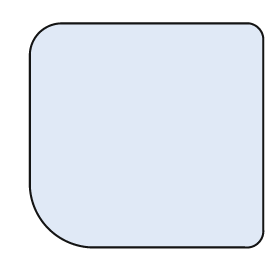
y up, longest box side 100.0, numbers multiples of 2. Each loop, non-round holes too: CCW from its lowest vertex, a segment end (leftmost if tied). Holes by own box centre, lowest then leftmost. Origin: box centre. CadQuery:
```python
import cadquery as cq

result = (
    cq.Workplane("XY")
    .moveTo(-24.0, -48.0)
    .lineTo(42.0, -48.0)
    .threePointArc((48.0, -46.0), (50.0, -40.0))
    .lineTo(50.0, 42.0)
    .threePointArc((48.0, 46.0), (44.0, 48.0))
    .lineTo(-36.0, 48.0)
    .threePointArc((-46.0, 44.0), (-50.0, 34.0))
    .lineTo(-50.0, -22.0)
    .threePointArc((-42.0, -40.0), (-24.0, -48.0))
    .close()
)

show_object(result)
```